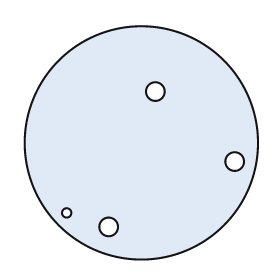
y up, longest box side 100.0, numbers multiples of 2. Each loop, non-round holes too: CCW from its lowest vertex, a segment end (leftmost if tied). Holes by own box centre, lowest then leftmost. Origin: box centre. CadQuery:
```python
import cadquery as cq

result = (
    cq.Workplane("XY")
    .moveTo(0.0, 0.0)
    .circle(50.0)
    .moveTo(-14.0, -36.0)
    .circle(4.0)
    .moveTo(-32.0, -30.0)
    .circle(2.0)
    .moveTo(40.0, -8.0)
    .circle(4.0)
    .moveTo(6.0, 22.0)
    .circle(4.0)
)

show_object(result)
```